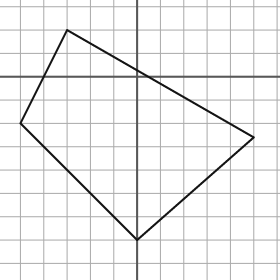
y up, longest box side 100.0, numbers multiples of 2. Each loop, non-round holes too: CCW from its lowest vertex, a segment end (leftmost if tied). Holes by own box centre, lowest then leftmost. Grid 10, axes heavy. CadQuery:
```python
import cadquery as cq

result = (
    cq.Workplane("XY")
    .moveTo(0.0, -70.0)
    .lineTo(50.0, -26.0)
    .lineTo(-30.0, 20.0)
    .lineTo(-50.0, -20.0)
    .close()
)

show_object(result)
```